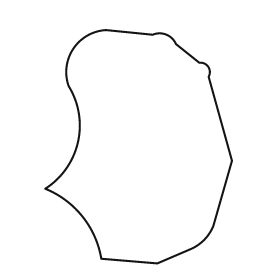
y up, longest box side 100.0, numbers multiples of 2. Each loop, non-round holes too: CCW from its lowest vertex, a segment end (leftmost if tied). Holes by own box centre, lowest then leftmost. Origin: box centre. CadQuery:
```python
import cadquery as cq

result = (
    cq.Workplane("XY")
    .moveTo(8.0, -50.0)
    .lineTo(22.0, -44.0)
    .threePointArc((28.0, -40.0), (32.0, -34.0))
    .lineTo(40.0, -6.0)
    .lineTo(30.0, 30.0)
    .threePointArc((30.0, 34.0), (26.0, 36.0))
    .lineTo(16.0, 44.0)
    .threePointArc((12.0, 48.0), (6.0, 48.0))
    .lineTo(-14.0, 50.0)
    .threePointArc((-28.0, 42.0), (-30.0, 26.0))
    .threePointArc((-26.0, 2.0), (-40.0, -18.0))
    .threePointArc((-24.0, -30.0), (-16.0, -48.0))
    .close()
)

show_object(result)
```